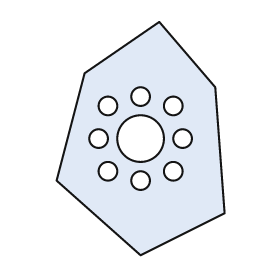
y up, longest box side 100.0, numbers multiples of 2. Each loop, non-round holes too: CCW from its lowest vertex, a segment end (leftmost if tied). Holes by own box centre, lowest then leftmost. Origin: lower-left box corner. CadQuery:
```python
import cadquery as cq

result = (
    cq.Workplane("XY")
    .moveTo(36.0, 0.0)
    .lineTo(72.0, 18.0)
    .lineTo(68.0, 72.0)
    .lineTo(44.0, 100.0)
    .lineTo(12.0, 78.0)
    .lineTo(0.0, 32.0)
    .close()
    .moveTo(36.0, 32.0)
    .circle(4.0)
    .moveTo(22.0, 36.0)
    .circle(4.0)
    .moveTo(50.0, 36.0)
    .circle(4.0)
    .moveTo(18.0, 50.0)
    .circle(4.0)
    .moveTo(36.0, 50.0)
    .circle(10.0)
    .moveTo(54.0, 50.0)
    .circle(4.0)
    .moveTo(22.0, 64.0)
    .circle(4.0)
    .moveTo(50.0, 64.0)
    .circle(4.0)
    .moveTo(36.0, 68.0)
    .circle(4.0)
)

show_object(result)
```